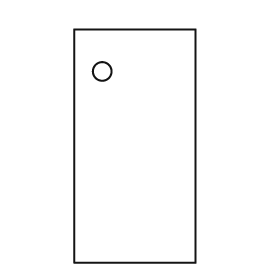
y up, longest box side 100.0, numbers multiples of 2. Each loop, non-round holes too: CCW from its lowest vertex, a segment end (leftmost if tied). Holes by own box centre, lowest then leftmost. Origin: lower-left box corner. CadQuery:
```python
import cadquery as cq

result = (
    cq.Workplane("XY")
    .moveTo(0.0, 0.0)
    .lineTo(52.0, 0.0)
    .lineTo(52.0, 100.0)
    .lineTo(0.0, 100.0)
    .close()
    .moveTo(12.0, 82.0)
    .circle(4.0)
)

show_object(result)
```